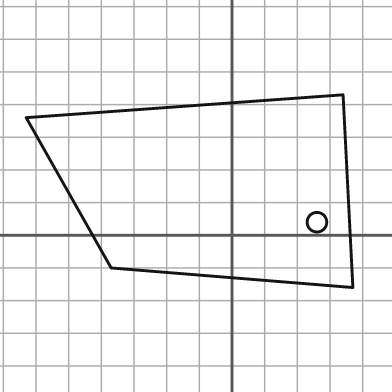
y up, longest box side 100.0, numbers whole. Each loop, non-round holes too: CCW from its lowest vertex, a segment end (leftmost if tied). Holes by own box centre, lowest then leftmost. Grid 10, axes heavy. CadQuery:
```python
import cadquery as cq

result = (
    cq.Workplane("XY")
    .moveTo(37.0, -16.0)
    .lineTo(34.0, 43.0)
    .lineTo(-63.0, 36.0)
    .lineTo(-37.0, -10.0)
    .close()
    .moveTo(26.0, 4.0)
    .circle(3.0)
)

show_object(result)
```